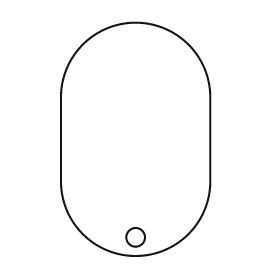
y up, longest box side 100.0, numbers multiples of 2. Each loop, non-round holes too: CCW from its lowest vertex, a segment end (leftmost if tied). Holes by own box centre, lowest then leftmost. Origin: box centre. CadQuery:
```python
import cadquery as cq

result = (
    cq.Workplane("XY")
    .moveTo(-32.0, -18.0)
    .threePointArc((0.0, -50.0), (32.0, -18.0))
    .lineTo(32.0, 18.0)
    .threePointArc((0.0, 50.0), (-32.0, 18.0))
    .close()
    .moveTo(0.0, -42.0)
    .circle(4.0)
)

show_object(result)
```